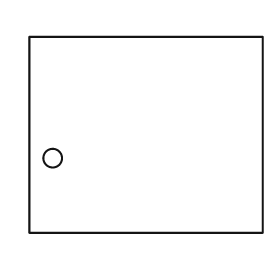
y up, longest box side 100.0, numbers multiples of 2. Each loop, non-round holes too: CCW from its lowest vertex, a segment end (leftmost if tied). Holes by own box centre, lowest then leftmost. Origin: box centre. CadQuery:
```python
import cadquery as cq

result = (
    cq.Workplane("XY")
    .moveTo(-50.0, -42.0)
    .lineTo(50.0, -42.0)
    .lineTo(50.0, 42.0)
    .lineTo(-50.0, 42.0)
    .close()
    .moveTo(-40.0, -10.0)
    .circle(4.0)
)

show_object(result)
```